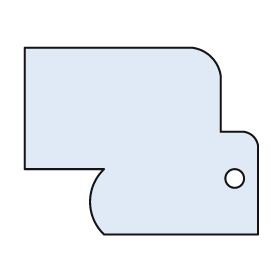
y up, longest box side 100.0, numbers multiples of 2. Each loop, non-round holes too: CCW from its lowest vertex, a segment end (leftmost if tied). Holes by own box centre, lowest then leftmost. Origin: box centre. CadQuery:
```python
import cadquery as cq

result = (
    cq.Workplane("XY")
    .moveTo(-16.0, -40.0)
    .lineTo(50.0, -40.0)
    .lineTo(50.0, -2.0)
    .threePointArc((48.0, 2.0), (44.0, 4.0))
    .lineTo(34.0, 4.0)
    .lineTo(34.0, 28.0)
    .threePointArc((30.0, 36.0), (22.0, 40.0))
    .lineTo(-50.0, 40.0)
    .lineTo(-50.0, -12.0)
    .lineTo(-16.0, -12.0)
    .threePointArc((-22.0, -26.0), (-16.0, -40.0))
    .close()
    .moveTo(40.0, -16.0)
    .circle(4.0)
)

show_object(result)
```